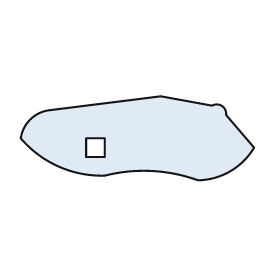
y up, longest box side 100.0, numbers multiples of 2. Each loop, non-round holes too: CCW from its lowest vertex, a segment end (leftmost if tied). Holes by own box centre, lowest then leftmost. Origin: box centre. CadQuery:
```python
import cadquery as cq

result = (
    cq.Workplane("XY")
    .moveTo(26.0, -18.0)
    .threePointArc((40.0, -14.0), (50.0, -4.0))
    .lineTo(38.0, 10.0)
    .threePointArc((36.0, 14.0), (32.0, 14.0))
    .lineTo(10.0, 18.0)
    .lineTo(-38.0, 12.0)
    .threePointArc((-46.0, 8.0), (-50.0, 0.0))
    .threePointArc((-34.0, -12.0), (-14.0, -16.0))
    .threePointArc((6.0, -14.0), (26.0, -18.0))
    .close()
    .moveTo(-22.0, -8.0)
    .lineTo(-14.0, -8.0)
    .lineTo(-14.0, 0.0)
    .lineTo(-22.0, 0.0)
    .close()
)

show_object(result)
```